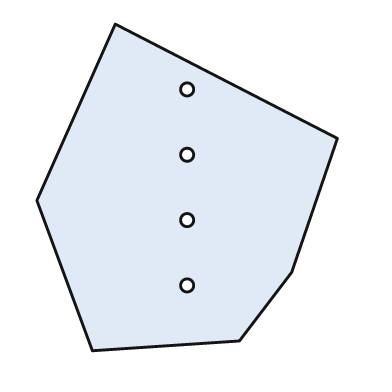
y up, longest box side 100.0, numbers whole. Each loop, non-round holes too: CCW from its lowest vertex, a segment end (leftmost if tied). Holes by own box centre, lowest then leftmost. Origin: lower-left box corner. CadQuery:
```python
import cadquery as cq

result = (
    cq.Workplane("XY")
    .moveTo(17.0, 0.0)
    .lineTo(62.0, 3.0)
    .lineTo(78.0, 24.0)
    .lineTo(92.0, 65.0)
    .lineTo(24.0, 100.0)
    .lineTo(0.0, 46.0)
    .close()
    .moveTo(46.0, 20.0)
    .circle(2.0)
    .moveTo(46.0, 40.0)
    .circle(2.0)
    .moveTo(46.0, 60.0)
    .circle(2.0)
    .moveTo(46.0, 80.0)
    .circle(2.0)
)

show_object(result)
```